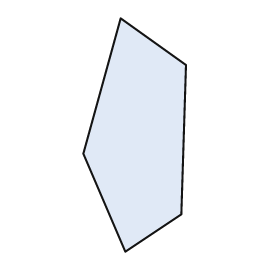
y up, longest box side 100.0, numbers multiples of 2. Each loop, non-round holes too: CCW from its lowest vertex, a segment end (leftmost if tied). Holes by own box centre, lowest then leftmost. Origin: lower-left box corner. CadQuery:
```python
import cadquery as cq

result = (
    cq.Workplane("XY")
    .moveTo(18.0, 0.0)
    .lineTo(42.0, 16.0)
    .lineTo(44.0, 80.0)
    .lineTo(16.0, 100.0)
    .lineTo(0.0, 42.0)
    .close()
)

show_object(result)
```